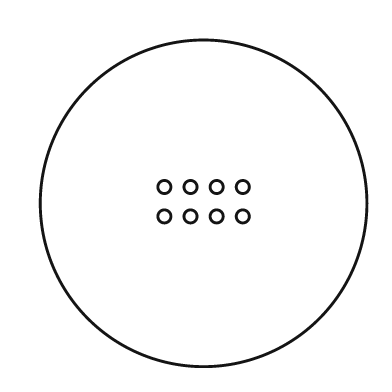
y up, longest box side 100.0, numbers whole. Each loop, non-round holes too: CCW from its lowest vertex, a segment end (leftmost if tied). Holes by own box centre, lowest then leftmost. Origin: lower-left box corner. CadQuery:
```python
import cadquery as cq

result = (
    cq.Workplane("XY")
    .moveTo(50.0, 50.0)
    .circle(50.0)
    .moveTo(38.0, 46.0)
    .circle(2.0)
    .moveTo(46.0, 46.0)
    .circle(2.0)
    .moveTo(54.0, 46.0)
    .circle(2.0)
    .moveTo(62.0, 46.0)
    .circle(2.0)
    .moveTo(38.0, 55.0)
    .circle(2.0)
    .moveTo(46.0, 55.0)
    .circle(2.0)
    .moveTo(54.0, 55.0)
    .circle(2.0)
    .moveTo(62.0, 55.0)
    .circle(2.0)
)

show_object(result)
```